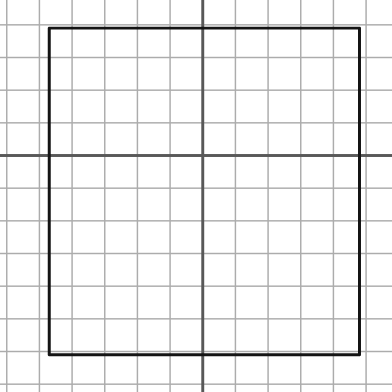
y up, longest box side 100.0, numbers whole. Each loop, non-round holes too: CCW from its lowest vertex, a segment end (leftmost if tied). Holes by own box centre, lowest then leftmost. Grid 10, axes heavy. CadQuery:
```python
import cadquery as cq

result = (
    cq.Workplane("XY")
    .moveTo(-47.0, -61.0)
    .lineTo(48.0, -61.0)
    .lineTo(48.0, 39.0)
    .lineTo(-47.0, 39.0)
    .close()
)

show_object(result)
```